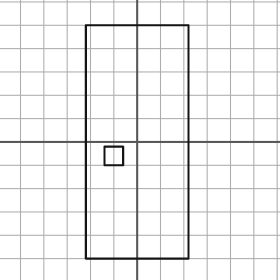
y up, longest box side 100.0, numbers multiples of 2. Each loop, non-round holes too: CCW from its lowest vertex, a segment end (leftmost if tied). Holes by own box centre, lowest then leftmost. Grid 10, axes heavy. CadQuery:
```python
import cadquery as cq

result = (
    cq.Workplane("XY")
    .moveTo(-22.0, -50.0)
    .lineTo(22.0, -50.0)
    .lineTo(22.0, 50.0)
    .lineTo(-22.0, 50.0)
    .close()
    .moveTo(-14.0, -10.0)
    .lineTo(-6.0, -10.0)
    .lineTo(-6.0, -2.0)
    .lineTo(-14.0, -2.0)
    .close()
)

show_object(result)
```